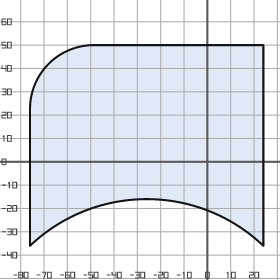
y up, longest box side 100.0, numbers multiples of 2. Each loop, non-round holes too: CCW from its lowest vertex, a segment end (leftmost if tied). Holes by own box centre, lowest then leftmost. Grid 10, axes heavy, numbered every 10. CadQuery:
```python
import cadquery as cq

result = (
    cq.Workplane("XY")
    .moveTo(-76.0, -36.0)
    .threePointArc((-26.0, -16.0), (24.0, -36.0))
    .lineTo(24.0, 50.0)
    .lineTo(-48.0, 50.0)
    .threePointArc((-68.0, 42.0), (-76.0, 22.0))
    .close()
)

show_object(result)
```